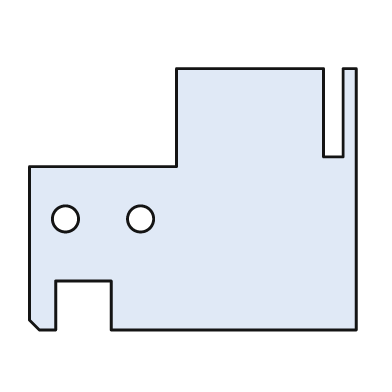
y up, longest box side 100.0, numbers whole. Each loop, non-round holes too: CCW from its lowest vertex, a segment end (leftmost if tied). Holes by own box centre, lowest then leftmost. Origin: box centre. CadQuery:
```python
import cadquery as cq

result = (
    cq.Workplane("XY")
    .moveTo(-47.0, -40.0)
    .lineTo(-42.0, -40.0)
    .lineTo(-42.0, -25.0)
    .lineTo(-25.0, -25.0)
    .lineTo(-25.0, -40.0)
    .lineTo(50.0, -40.0)
    .lineTo(50.0, 40.0)
    .lineTo(46.0, 40.0)
    .lineTo(46.0, 13.0)
    .lineTo(40.0, 13.0)
    .lineTo(40.0, 40.0)
    .lineTo(-5.0, 40.0)
    .lineTo(-5.0, 10.0)
    .lineTo(-50.0, 10.0)
    .lineTo(-50.0, -37.0)
    .close()
    .moveTo(-39.0, -6.0)
    .circle(4.0)
    .moveTo(-16.0, -6.0)
    .circle(4.0)
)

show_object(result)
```